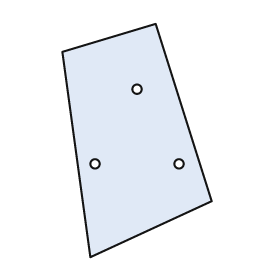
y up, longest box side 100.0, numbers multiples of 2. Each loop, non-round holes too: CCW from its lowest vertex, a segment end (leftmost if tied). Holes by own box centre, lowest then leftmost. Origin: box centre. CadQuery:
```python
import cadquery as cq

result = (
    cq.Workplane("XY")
    .moveTo(-20.0, -50.0)
    .lineTo(32.0, -26.0)
    .lineTo(8.0, 50.0)
    .lineTo(-32.0, 38.0)
    .close()
    .moveTo(-18.0, -10.0)
    .circle(2.0)
    .moveTo(18.0, -10.0)
    .circle(2.0)
    .moveTo(0.0, 22.0)
    .circle(2.0)
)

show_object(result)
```